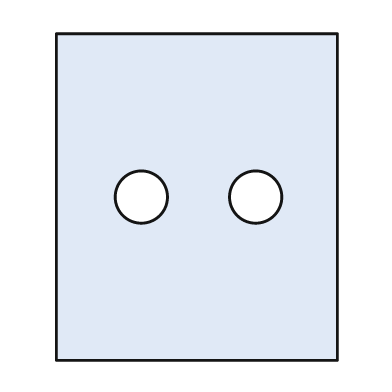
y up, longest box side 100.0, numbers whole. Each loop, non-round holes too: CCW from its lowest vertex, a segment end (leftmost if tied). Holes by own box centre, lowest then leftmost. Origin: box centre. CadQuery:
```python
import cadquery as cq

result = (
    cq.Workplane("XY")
    .moveTo(-43.0, -50.0)
    .lineTo(43.0, -50.0)
    .lineTo(43.0, 50.0)
    .lineTo(-43.0, 50.0)
    .close()
    .moveTo(-17.0, 0.0)
    .circle(8.0)
    .moveTo(18.0, 0.0)
    .circle(8.0)
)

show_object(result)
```